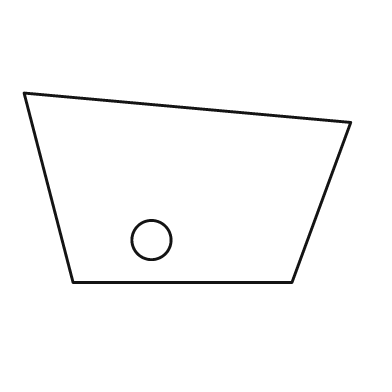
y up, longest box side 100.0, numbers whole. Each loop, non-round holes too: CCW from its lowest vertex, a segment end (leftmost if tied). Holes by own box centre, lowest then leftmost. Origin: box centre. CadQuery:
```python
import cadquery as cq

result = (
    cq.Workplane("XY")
    .moveTo(-35.0, -29.0)
    .lineTo(32.0, -29.0)
    .lineTo(50.0, 20.0)
    .lineTo(-50.0, 29.0)
    .close()
    .moveTo(-11.0, -16.0)
    .circle(6.0)
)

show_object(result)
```